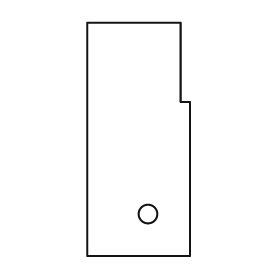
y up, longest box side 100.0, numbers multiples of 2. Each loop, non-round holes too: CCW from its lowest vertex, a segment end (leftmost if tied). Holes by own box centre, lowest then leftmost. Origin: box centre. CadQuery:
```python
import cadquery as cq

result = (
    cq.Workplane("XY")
    .moveTo(-22.0, -50.0)
    .lineTo(22.0, -50.0)
    .lineTo(22.0, 16.0)
    .lineTo(18.0, 16.0)
    .lineTo(18.0, 50.0)
    .lineTo(-22.0, 50.0)
    .close()
    .moveTo(4.0, -32.0)
    .circle(4.0)
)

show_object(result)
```